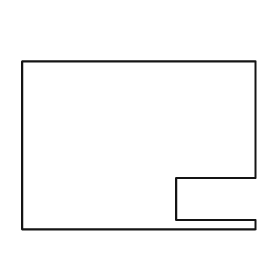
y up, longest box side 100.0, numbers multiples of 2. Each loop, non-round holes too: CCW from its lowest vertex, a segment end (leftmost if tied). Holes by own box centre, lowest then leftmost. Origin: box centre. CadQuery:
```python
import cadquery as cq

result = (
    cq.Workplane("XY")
    .moveTo(-50.0, -36.0)
    .lineTo(50.0, -36.0)
    .lineTo(50.0, -32.0)
    .lineTo(16.0, -32.0)
    .lineTo(16.0, -14.0)
    .lineTo(50.0, -14.0)
    .lineTo(50.0, 36.0)
    .lineTo(-50.0, 36.0)
    .close()
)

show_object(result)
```